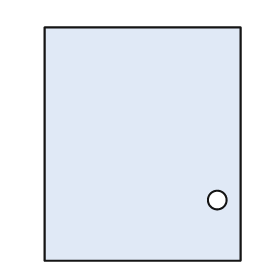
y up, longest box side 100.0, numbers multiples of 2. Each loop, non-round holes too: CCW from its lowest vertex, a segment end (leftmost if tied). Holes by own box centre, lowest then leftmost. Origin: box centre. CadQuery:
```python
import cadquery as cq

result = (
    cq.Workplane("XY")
    .moveTo(-42.0, -50.0)
    .lineTo(42.0, -50.0)
    .lineTo(42.0, 50.0)
    .lineTo(-42.0, 50.0)
    .close()
    .moveTo(32.0, -24.0)
    .circle(4.0)
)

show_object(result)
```